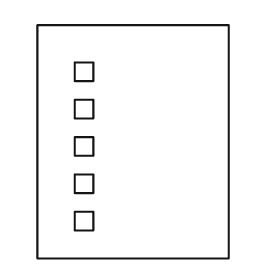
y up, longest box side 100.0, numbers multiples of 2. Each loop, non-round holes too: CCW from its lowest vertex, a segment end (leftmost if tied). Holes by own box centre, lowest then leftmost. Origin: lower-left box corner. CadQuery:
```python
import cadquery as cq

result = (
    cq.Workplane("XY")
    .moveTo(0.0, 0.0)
    .lineTo(82.0, 0.0)
    .lineTo(82.0, 100.0)
    .lineTo(0.0, 100.0)
    .close()
    .moveTo(16.0, 12.0)
    .lineTo(24.0, 12.0)
    .lineTo(24.0, 20.0)
    .lineTo(16.0, 20.0)
    .close()
    .moveTo(16.0, 28.0)
    .lineTo(24.0, 28.0)
    .lineTo(24.0, 36.0)
    .lineTo(16.0, 36.0)
    .close()
    .moveTo(16.0, 44.0)
    .lineTo(24.0, 44.0)
    .lineTo(24.0, 52.0)
    .lineTo(16.0, 52.0)
    .close()
    .moveTo(16.0, 60.0)
    .lineTo(24.0, 60.0)
    .lineTo(24.0, 68.0)
    .lineTo(16.0, 68.0)
    .close()
    .moveTo(16.0, 76.0)
    .lineTo(24.0, 76.0)
    .lineTo(24.0, 84.0)
    .lineTo(16.0, 84.0)
    .close()
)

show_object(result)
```